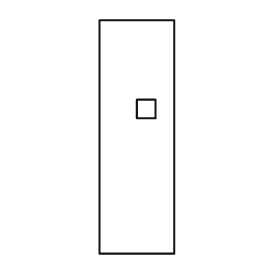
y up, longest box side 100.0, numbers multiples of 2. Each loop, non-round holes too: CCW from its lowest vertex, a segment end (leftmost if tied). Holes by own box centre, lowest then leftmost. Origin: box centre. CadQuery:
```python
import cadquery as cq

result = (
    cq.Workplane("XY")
    .moveTo(-16.0, -50.0)
    .lineTo(16.0, -50.0)
    .lineTo(16.0, 50.0)
    .lineTo(-16.0, 50.0)
    .close()
    .moveTo(0.0, 8.0)
    .lineTo(8.0, 8.0)
    .lineTo(8.0, 16.0)
    .lineTo(0.0, 16.0)
    .close()
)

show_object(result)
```